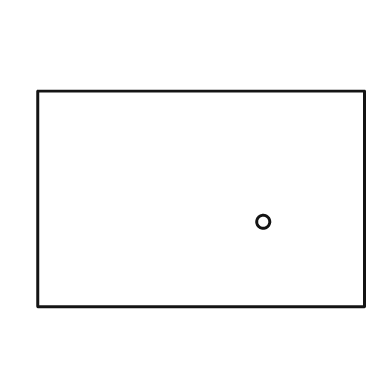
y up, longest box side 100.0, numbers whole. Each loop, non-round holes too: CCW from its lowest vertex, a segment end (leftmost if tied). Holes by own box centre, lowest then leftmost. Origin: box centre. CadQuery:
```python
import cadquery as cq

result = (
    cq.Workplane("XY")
    .moveTo(-50.0, -33.0)
    .lineTo(50.0, -33.0)
    .lineTo(50.0, 33.0)
    .lineTo(-50.0, 33.0)
    .close()
    .moveTo(19.0, -7.0)
    .circle(2.0)
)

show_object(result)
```